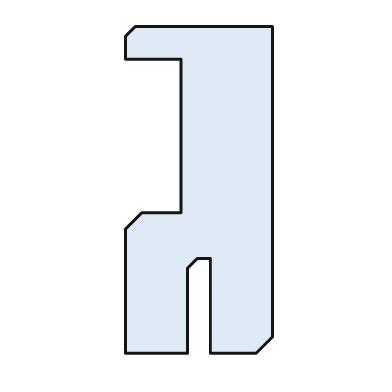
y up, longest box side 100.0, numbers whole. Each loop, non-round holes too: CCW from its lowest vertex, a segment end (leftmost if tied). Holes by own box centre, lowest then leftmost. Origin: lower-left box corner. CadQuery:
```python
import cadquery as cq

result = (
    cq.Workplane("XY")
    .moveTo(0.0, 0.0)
    .lineTo(19.0, 0.0)
    .lineTo(19.0, 26.0)
    .lineTo(22.0, 29.0)
    .lineTo(26.0, 29.0)
    .lineTo(26.0, 0.0)
    .lineTo(40.0, 0.0)
    .lineTo(45.0, 5.0)
    .lineTo(45.0, 100.0)
    .lineTo(3.0, 100.0)
    .lineTo(0.0, 97.0)
    .lineTo(0.0, 90.0)
    .lineTo(17.0, 90.0)
    .lineTo(17.0, 43.0)
    .lineTo(5.0, 43.0)
    .lineTo(0.0, 38.0)
    .close()
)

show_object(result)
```